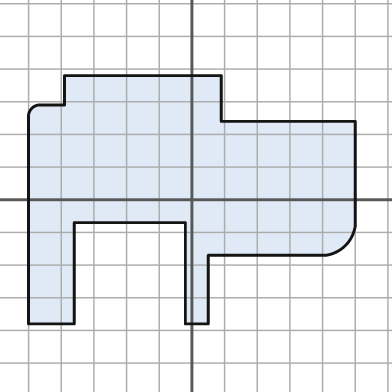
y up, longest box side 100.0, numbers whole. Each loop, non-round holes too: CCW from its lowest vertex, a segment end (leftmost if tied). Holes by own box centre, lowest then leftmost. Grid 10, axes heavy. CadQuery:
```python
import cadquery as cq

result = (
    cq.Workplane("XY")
    .moveTo(-50.0, -38.0)
    .lineTo(-36.0, -38.0)
    .lineTo(-36.0, -7.0)
    .lineTo(-2.0, -7.0)
    .lineTo(-2.0, -38.0)
    .lineTo(5.0, -38.0)
    .lineTo(5.0, -17.0)
    .lineTo(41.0, -17.0)
    .threePointArc((47.0, -14.0), (50.0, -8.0))
    .lineTo(50.0, 24.0)
    .lineTo(9.0, 24.0)
    .lineTo(9.0, 38.0)
    .lineTo(-39.0, 38.0)
    .lineTo(-39.0, 29.0)
    .lineTo(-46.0, 29.0)
    .threePointArc((-49.0, 28.0), (-50.0, 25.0))
    .close()
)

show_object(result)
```